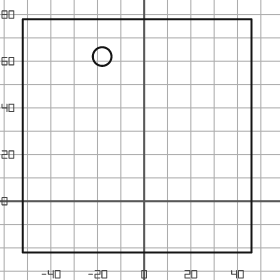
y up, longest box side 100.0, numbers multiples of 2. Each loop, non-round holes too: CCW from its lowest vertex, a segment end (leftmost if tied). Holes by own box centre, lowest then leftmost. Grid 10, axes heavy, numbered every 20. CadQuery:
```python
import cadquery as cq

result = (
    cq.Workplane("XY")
    .moveTo(-52.0, -22.0)
    .lineTo(46.0, -22.0)
    .lineTo(46.0, 78.0)
    .lineTo(-52.0, 78.0)
    .close()
    .moveTo(-18.0, 62.0)
    .circle(4.0)
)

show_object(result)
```